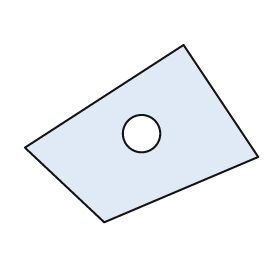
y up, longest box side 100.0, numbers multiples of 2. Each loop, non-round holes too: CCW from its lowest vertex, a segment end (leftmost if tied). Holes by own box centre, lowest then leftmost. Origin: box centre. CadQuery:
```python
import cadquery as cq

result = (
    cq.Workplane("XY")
    .moveTo(-16.0, -38.0)
    .lineTo(50.0, -10.0)
    .lineTo(18.0, 38.0)
    .lineTo(-50.0, -6.0)
    .close()
    .moveTo(0.0, 0.0)
    .circle(8.0)
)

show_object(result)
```